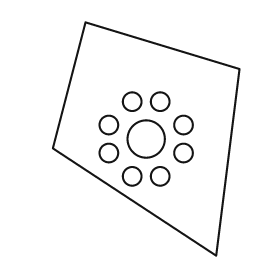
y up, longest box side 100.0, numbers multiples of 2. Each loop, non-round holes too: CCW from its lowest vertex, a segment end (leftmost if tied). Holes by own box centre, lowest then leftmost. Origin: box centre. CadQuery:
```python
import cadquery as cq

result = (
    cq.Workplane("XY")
    .moveTo(30.0, -50.0)
    .lineTo(40.0, 30.0)
    .lineTo(-26.0, 50.0)
    .lineTo(-40.0, -4.0)
    .close()
    .moveTo(-6.0, -16.0)
    .circle(4.0)
    .moveTo(6.0, -16.0)
    .circle(4.0)
    .moveTo(-16.0, -6.0)
    .circle(4.0)
    .moveTo(16.0, -6.0)
    .circle(4.0)
    .moveTo(0.0, 0.0)
    .circle(8.0)
    .moveTo(-16.0, 6.0)
    .circle(4.0)
    .moveTo(16.0, 6.0)
    .circle(4.0)
    .moveTo(-6.0, 16.0)
    .circle(4.0)
    .moveTo(6.0, 16.0)
    .circle(4.0)
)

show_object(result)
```